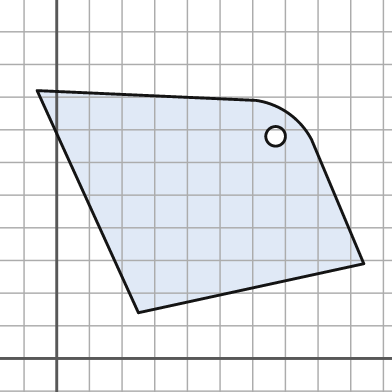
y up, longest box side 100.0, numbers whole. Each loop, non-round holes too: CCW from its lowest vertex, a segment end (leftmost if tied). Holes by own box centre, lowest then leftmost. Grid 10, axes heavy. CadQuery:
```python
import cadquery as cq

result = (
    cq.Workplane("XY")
    .moveTo(25.0, 14.0)
    .lineTo(94.0, 29.0)
    .lineTo(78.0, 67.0)
    .threePointArc((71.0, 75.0), (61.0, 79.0))
    .lineTo(-6.0, 82.0)
    .close()
    .moveTo(67.0, 68.0)
    .circle(3.0)
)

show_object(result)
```